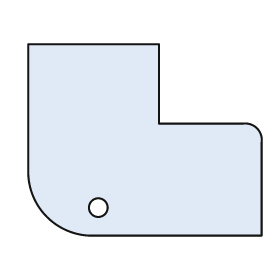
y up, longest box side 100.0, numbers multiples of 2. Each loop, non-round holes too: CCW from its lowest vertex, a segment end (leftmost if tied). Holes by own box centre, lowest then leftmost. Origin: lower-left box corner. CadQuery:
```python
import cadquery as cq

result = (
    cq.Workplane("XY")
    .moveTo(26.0, 0.0)
    .lineTo(100.0, 0.0)
    .lineTo(100.0, 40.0)
    .threePointArc((98.0, 46.0), (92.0, 48.0))
    .lineTo(56.0, 48.0)
    .lineTo(56.0, 82.0)
    .lineTo(0.0, 82.0)
    .lineTo(0.0, 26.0)
    .threePointArc((8.0, 8.0), (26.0, 0.0))
    .close()
    .moveTo(30.0, 12.0)
    .circle(4.0)
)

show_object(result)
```